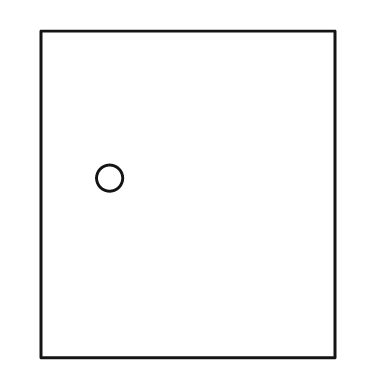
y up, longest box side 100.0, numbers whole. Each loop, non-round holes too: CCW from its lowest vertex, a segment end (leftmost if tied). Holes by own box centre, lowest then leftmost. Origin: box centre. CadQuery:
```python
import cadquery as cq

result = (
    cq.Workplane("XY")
    .moveTo(-45.0, -50.0)
    .lineTo(45.0, -50.0)
    .lineTo(45.0, 50.0)
    .lineTo(-45.0, 50.0)
    .close()
    .moveTo(-24.0, 5.0)
    .circle(4.0)
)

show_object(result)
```